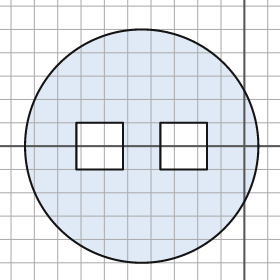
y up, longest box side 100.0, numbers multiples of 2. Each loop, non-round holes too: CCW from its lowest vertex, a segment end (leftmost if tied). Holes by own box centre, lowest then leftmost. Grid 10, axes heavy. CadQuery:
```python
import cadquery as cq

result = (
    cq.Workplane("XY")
    .moveTo(-44.0, 0.0)
    .circle(50.0)
    .moveTo(-72.0, -10.0)
    .lineTo(-52.0, -10.0)
    .lineTo(-52.0, 10.0)
    .lineTo(-72.0, 10.0)
    .close()
    .moveTo(-36.0, -10.0)
    .lineTo(-16.0, -10.0)
    .lineTo(-16.0, 10.0)
    .lineTo(-36.0, 10.0)
    .close()
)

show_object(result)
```